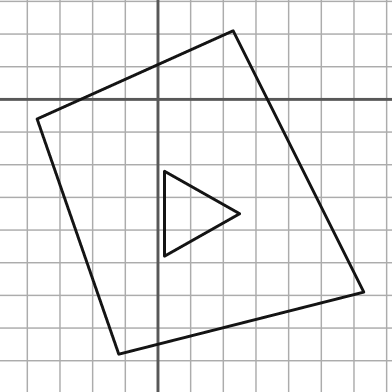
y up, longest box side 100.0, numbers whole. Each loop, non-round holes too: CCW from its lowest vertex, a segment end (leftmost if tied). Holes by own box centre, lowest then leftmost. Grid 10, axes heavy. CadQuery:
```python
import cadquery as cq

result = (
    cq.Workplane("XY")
    .moveTo(-12.0, -78.0)
    .lineTo(63.0, -59.0)
    .lineTo(23.0, 21.0)
    .lineTo(-37.0, -6.0)
    .close()
    .moveTo(2.0, -48.0)
    .lineTo(25.0, -35.0)
    .lineTo(2.0, -22.0)
    .close()
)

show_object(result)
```